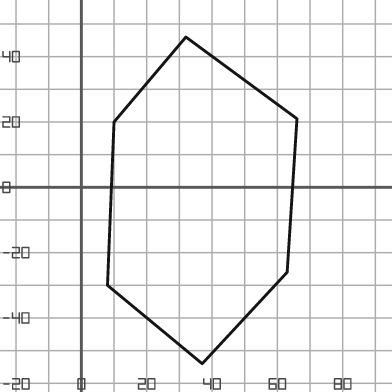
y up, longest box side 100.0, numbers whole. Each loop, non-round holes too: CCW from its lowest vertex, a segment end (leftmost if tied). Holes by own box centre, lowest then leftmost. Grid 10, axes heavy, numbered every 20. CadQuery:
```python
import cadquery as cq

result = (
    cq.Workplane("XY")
    .moveTo(37.0, -54.0)
    .lineTo(63.0, -26.0)
    .lineTo(66.0, 21.0)
    .lineTo(32.0, 46.0)
    .lineTo(10.0, 20.0)
    .lineTo(8.0, -30.0)
    .close()
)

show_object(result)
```